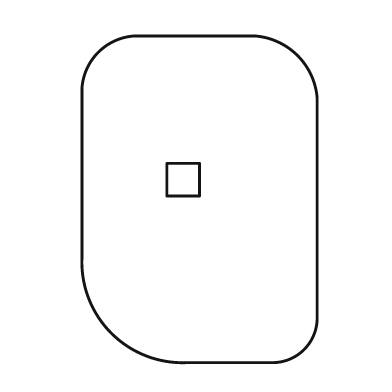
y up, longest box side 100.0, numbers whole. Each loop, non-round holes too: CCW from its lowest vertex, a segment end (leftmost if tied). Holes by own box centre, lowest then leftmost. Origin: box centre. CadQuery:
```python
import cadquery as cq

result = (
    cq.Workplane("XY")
    .moveTo(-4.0, -50.0)
    .lineTo(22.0, -50.0)
    .threePointArc((32.0, -46.0), (36.0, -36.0))
    .lineTo(36.0, 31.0)
    .threePointArc((30.0, 44.0), (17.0, 50.0))
    .lineTo(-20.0, 50.0)
    .threePointArc((-31.0, 45.0), (-36.0, 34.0))
    .lineTo(-36.0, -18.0)
    .threePointArc((-27.0, -41.0), (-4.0, -50.0))
    .close()
    .moveTo(-10.0, 1.0)
    .lineTo(0.0, 1.0)
    .lineTo(0.0, 11.0)
    .lineTo(-10.0, 11.0)
    .close()
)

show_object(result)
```